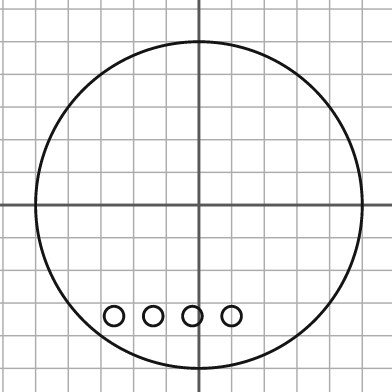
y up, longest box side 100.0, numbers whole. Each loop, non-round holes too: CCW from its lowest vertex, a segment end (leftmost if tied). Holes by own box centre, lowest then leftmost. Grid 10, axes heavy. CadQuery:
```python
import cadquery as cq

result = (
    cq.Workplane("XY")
    .moveTo(0.0, 0.0)
    .circle(50.0)
    .moveTo(-26.0, -34.0)
    .circle(3.0)
    .moveTo(-14.0, -34.0)
    .circle(3.0)
    .moveTo(-2.0, -34.0)
    .circle(3.0)
    .moveTo(10.0, -34.0)
    .circle(3.0)
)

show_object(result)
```